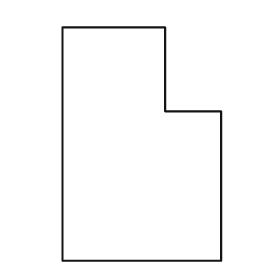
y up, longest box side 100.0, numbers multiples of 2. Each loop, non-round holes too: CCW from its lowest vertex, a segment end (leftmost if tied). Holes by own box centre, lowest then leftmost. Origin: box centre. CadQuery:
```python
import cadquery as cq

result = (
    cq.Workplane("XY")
    .moveTo(-34.0, -50.0)
    .lineTo(34.0, -50.0)
    .lineTo(34.0, 14.0)
    .lineTo(10.0, 14.0)
    .lineTo(10.0, 50.0)
    .lineTo(-34.0, 50.0)
    .close()
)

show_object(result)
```